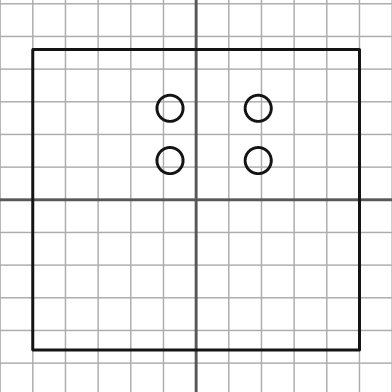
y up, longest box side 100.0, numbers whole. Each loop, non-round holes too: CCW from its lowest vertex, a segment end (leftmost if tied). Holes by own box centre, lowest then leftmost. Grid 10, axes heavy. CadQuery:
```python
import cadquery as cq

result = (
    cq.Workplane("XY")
    .moveTo(-50.0, -46.0)
    .lineTo(50.0, -46.0)
    .lineTo(50.0, 46.0)
    .lineTo(-50.0, 46.0)
    .close()
    .moveTo(-8.0, 12.0)
    .circle(4.0)
    .moveTo(19.0, 12.0)
    .circle(4.0)
    .moveTo(-8.0, 28.0)
    .circle(4.0)
    .moveTo(19.0, 28.0)
    .circle(4.0)
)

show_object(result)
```